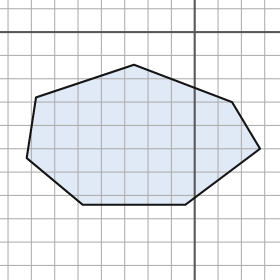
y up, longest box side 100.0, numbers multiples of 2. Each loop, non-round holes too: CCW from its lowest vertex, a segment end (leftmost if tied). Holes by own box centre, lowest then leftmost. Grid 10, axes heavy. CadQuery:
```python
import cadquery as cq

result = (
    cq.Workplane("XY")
    .moveTo(-48.0, -74.0)
    .lineTo(-4.0, -74.0)
    .lineTo(28.0, -50.0)
    .lineTo(16.0, -30.0)
    .lineTo(-26.0, -14.0)
    .lineTo(-68.0, -28.0)
    .lineTo(-72.0, -54.0)
    .close()
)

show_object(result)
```